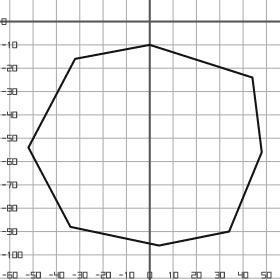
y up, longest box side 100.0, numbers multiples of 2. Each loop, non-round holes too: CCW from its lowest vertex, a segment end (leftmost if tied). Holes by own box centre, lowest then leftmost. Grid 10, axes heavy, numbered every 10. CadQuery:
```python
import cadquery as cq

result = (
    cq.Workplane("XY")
    .moveTo(4.0, -96.0)
    .lineTo(34.0, -90.0)
    .lineTo(48.0, -56.0)
    .lineTo(44.0, -24.0)
    .lineTo(0.0, -10.0)
    .lineTo(-32.0, -16.0)
    .lineTo(-52.0, -54.0)
    .lineTo(-34.0, -88.0)
    .close()
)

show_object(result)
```